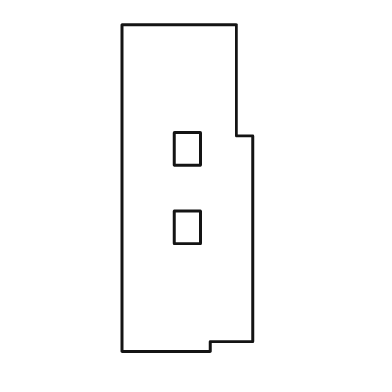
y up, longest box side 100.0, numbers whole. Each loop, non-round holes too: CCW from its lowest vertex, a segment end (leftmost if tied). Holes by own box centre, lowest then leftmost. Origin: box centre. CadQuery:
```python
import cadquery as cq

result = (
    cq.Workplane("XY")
    .moveTo(-20.0, -50.0)
    .lineTo(7.0, -50.0)
    .lineTo(7.0, -47.0)
    .lineTo(20.0, -47.0)
    .lineTo(20.0, 16.0)
    .lineTo(15.0, 16.0)
    .lineTo(15.0, 50.0)
    .lineTo(-20.0, 50.0)
    .close()
    .moveTo(-4.0, -17.0)
    .lineTo(4.0, -17.0)
    .lineTo(4.0, -7.0)
    .lineTo(-4.0, -7.0)
    .close()
    .moveTo(-4.0, 7.0)
    .lineTo(4.0, 7.0)
    .lineTo(4.0, 17.0)
    .lineTo(-4.0, 17.0)
    .close()
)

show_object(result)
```